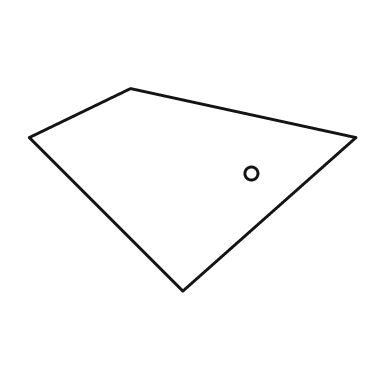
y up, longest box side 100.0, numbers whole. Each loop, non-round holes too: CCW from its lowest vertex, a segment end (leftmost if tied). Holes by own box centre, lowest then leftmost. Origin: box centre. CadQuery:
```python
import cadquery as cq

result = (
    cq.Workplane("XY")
    .moveTo(-3.0, -31.0)
    .lineTo(50.0, 16.0)
    .lineTo(-19.0, 31.0)
    .lineTo(-50.0, 16.0)
    .close()
    .moveTo(18.0, 5.0)
    .circle(2.0)
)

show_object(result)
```